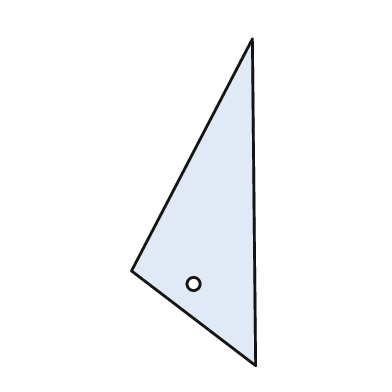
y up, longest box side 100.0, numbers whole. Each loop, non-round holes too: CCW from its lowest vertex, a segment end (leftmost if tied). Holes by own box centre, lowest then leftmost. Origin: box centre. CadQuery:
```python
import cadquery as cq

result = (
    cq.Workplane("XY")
    .moveTo(19.0, -50.0)
    .lineTo(18.0, 50.0)
    .lineTo(-19.0, -21.0)
    .close()
    .moveTo(0.0, -25.0)
    .circle(2.0)
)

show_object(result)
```